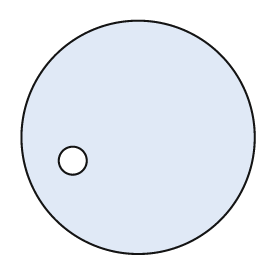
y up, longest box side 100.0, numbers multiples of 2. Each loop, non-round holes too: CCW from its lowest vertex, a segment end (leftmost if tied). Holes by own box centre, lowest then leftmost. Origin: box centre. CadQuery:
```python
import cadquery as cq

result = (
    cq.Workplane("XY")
    .moveTo(0.0, 0.0)
    .circle(50.0)
    .moveTo(-28.0, -10.0)
    .circle(6.0)
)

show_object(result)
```